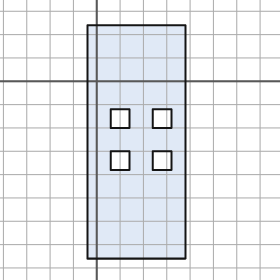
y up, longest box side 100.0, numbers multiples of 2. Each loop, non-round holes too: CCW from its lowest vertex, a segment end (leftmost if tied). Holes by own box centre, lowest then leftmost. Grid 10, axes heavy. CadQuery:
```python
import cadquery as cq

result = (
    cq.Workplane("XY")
    .moveTo(-4.0, -76.0)
    .lineTo(38.0, -76.0)
    .lineTo(38.0, 24.0)
    .lineTo(-4.0, 24.0)
    .close()
    .moveTo(6.0, -38.0)
    .lineTo(14.0, -38.0)
    .lineTo(14.0, -30.0)
    .lineTo(6.0, -30.0)
    .close()
    .moveTo(24.0, -38.0)
    .lineTo(32.0, -38.0)
    .lineTo(32.0, -30.0)
    .lineTo(24.0, -30.0)
    .close()
    .moveTo(6.0, -20.0)
    .lineTo(14.0, -20.0)
    .lineTo(14.0, -12.0)
    .lineTo(6.0, -12.0)
    .close()
    .moveTo(24.0, -20.0)
    .lineTo(32.0, -20.0)
    .lineTo(32.0, -12.0)
    .lineTo(24.0, -12.0)
    .close()
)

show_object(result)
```